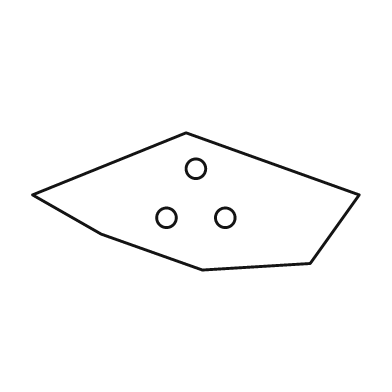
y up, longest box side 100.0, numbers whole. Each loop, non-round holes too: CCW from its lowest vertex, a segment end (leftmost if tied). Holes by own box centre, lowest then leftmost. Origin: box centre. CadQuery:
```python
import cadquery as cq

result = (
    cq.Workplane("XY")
    .moveTo(2.0, -21.0)
    .lineTo(35.0, -19.0)
    .lineTo(50.0, 2.0)
    .lineTo(-3.0, 21.0)
    .lineTo(-50.0, 2.0)
    .lineTo(-29.0, -10.0)
    .close()
    .moveTo(-9.0, -5.0)
    .circle(3.0)
    .moveTo(9.0, -5.0)
    .circle(3.0)
    .moveTo(0.0, 10.0)
    .circle(3.0)
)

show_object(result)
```